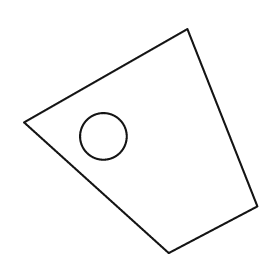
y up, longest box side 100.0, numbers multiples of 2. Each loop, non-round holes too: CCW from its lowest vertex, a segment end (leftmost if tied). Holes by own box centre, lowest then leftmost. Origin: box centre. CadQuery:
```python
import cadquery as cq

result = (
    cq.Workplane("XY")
    .moveTo(12.0, -48.0)
    .lineTo(50.0, -28.0)
    .lineTo(20.0, 48.0)
    .lineTo(-50.0, 8.0)
    .close()
    .moveTo(-16.0, 2.0)
    .circle(10.0)
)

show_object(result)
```